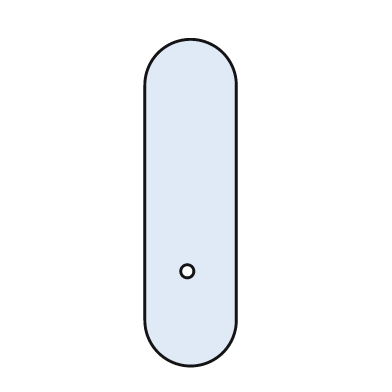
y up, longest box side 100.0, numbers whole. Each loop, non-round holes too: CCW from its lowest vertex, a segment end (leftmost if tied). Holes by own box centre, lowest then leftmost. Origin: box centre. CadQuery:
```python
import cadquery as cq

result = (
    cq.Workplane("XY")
    .moveTo(-14.0, -36.0)
    .threePointArc((0.0, -50.0), (14.0, -36.0))
    .lineTo(14.0, 36.0)
    .threePointArc((0.0, 50.0), (-14.0, 36.0))
    .close()
    .moveTo(-1.0, -21.0)
    .circle(2.0)
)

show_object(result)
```